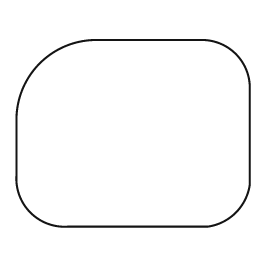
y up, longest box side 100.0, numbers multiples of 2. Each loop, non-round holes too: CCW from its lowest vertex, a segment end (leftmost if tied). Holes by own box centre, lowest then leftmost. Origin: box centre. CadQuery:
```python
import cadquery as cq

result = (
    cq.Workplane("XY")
    .moveTo(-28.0, -40.0)
    .lineTo(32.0, -40.0)
    .threePointArc((44.0, -34.0), (50.0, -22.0))
    .lineTo(50.0, 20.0)
    .threePointArc((44.0, 34.0), (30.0, 40.0))
    .lineTo(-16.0, 40.0)
    .threePointArc((-40.0, 30.0), (-50.0, 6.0))
    .lineTo(-50.0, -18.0)
    .threePointArc((-44.0, -34.0), (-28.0, -40.0))
    .close()
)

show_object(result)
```